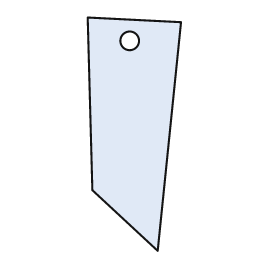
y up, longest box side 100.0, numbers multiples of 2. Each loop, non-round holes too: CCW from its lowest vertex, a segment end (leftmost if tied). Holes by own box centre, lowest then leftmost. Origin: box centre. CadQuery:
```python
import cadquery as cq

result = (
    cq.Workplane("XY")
    .moveTo(10.0, -50.0)
    .lineTo(20.0, 48.0)
    .lineTo(-20.0, 50.0)
    .lineTo(-18.0, -24.0)
    .close()
    .moveTo(-2.0, 40.0)
    .circle(4.0)
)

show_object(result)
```